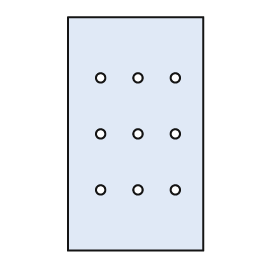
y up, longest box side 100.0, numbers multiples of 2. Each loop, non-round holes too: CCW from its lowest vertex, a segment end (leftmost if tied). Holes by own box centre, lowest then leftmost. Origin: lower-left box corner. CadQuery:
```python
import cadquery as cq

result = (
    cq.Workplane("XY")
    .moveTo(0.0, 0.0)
    .lineTo(58.0, 0.0)
    .lineTo(58.0, 100.0)
    .lineTo(0.0, 100.0)
    .close()
    .moveTo(14.0, 26.0)
    .circle(2.0)
    .moveTo(30.0, 26.0)
    .circle(2.0)
    .moveTo(46.0, 26.0)
    .circle(2.0)
    .moveTo(14.0, 50.0)
    .circle(2.0)
    .moveTo(30.0, 50.0)
    .circle(2.0)
    .moveTo(46.0, 50.0)
    .circle(2.0)
    .moveTo(14.0, 74.0)
    .circle(2.0)
    .moveTo(30.0, 74.0)
    .circle(2.0)
    .moveTo(46.0, 74.0)
    .circle(2.0)
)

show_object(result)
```